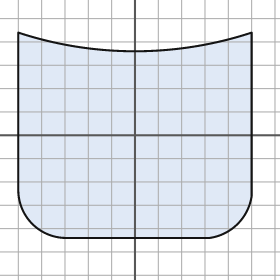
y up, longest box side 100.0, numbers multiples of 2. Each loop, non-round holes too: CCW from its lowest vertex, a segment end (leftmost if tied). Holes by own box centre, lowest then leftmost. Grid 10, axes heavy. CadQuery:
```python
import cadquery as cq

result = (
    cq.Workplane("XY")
    .moveTo(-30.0, -44.0)
    .lineTo(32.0, -44.0)
    .threePointArc((44.0, -38.0), (50.0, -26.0))
    .lineTo(50.0, 44.0)
    .threePointArc((0.0, 36.0), (-50.0, 44.0))
    .lineTo(-50.0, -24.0)
    .threePointArc((-44.0, -38.0), (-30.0, -44.0))
    .close()
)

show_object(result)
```